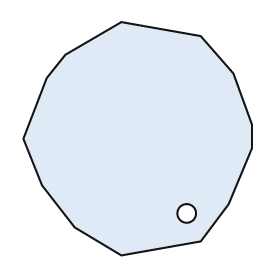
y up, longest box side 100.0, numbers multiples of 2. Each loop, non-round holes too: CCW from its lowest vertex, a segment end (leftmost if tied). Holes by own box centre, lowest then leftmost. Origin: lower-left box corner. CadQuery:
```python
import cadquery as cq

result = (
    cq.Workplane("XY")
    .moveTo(42.0, 0.0)
    .lineTo(76.0, 6.0)
    .lineTo(88.0, 22.0)
    .lineTo(98.0, 46.0)
    .lineTo(98.0, 56.0)
    .lineTo(90.0, 78.0)
    .lineTo(76.0, 94.0)
    .lineTo(42.0, 100.0)
    .lineTo(18.0, 86.0)
    .lineTo(10.0, 76.0)
    .lineTo(0.0, 50.0)
    .lineTo(8.0, 30.0)
    .lineTo(22.0, 12.0)
    .close()
    .moveTo(70.0, 18.0)
    .circle(4.0)
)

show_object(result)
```